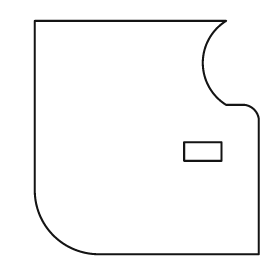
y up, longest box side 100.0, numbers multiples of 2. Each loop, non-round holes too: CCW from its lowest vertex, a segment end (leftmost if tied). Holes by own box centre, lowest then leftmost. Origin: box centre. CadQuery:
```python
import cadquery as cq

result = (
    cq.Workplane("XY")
    .moveTo(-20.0, -50.0)
    .lineTo(48.0, -50.0)
    .lineTo(48.0, 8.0)
    .threePointArc((46.0, 12.0), (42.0, 14.0))
    .lineTo(34.0, 14.0)
    .threePointArc((24.0, 32.0), (34.0, 50.0))
    .lineTo(-48.0, 50.0)
    .lineTo(-48.0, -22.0)
    .threePointArc((-40.0, -42.0), (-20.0, -50.0))
    .close()
    .moveTo(16.0, -10.0)
    .lineTo(32.0, -10.0)
    .lineTo(32.0, -2.0)
    .lineTo(16.0, -2.0)
    .close()
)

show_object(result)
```